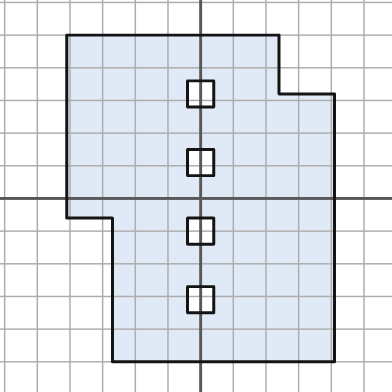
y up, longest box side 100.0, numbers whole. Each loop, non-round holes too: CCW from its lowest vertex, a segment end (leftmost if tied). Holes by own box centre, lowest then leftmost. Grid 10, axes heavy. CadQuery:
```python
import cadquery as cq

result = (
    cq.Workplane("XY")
    .moveTo(-27.0, -50.0)
    .lineTo(41.0, -50.0)
    .lineTo(41.0, 32.0)
    .lineTo(24.0, 32.0)
    .lineTo(24.0, 50.0)
    .lineTo(-41.0, 50.0)
    .lineTo(-41.0, -6.0)
    .lineTo(-27.0, -6.0)
    .close()
    .moveTo(-4.0, -35.0)
    .lineTo(4.0, -35.0)
    .lineTo(4.0, -27.0)
    .lineTo(-4.0, -27.0)
    .close()
    .moveTo(-4.0, -14.0)
    .lineTo(4.0, -14.0)
    .lineTo(4.0, -6.0)
    .lineTo(-4.0, -6.0)
    .close()
    .moveTo(-4.0, 7.0)
    .lineTo(4.0, 7.0)
    .lineTo(4.0, 15.0)
    .lineTo(-4.0, 15.0)
    .close()
    .moveTo(-4.0, 28.0)
    .lineTo(4.0, 28.0)
    .lineTo(4.0, 36.0)
    .lineTo(-4.0, 36.0)
    .close()
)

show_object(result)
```